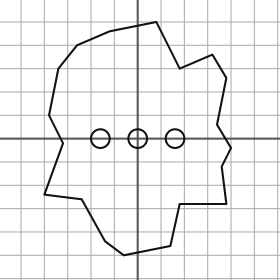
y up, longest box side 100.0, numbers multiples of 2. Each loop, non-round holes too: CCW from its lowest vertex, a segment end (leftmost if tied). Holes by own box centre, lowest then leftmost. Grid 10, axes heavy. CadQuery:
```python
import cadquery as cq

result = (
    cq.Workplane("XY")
    .moveTo(-6.0, -50.0)
    .lineTo(14.0, -46.0)
    .lineTo(18.0, -28.0)
    .lineTo(38.0, -28.0)
    .lineTo(36.0, -12.0)
    .lineTo(40.0, -4.0)
    .lineTo(34.0, 6.0)
    .lineTo(38.0, 26.0)
    .lineTo(32.0, 36.0)
    .lineTo(18.0, 30.0)
    .lineTo(8.0, 50.0)
    .lineTo(-12.0, 46.0)
    .lineTo(-26.0, 40.0)
    .lineTo(-34.0, 30.0)
    .lineTo(-38.0, 10.0)
    .lineTo(-32.0, -2.0)
    .lineTo(-40.0, -24.0)
    .lineTo(-24.0, -26.0)
    .lineTo(-14.0, -44.0)
    .close()
    .moveTo(-16.0, 0.0)
    .circle(4.0)
    .moveTo(0.0, 0.0)
    .circle(4.0)
    .moveTo(16.0, 0.0)
    .circle(4.0)
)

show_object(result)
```